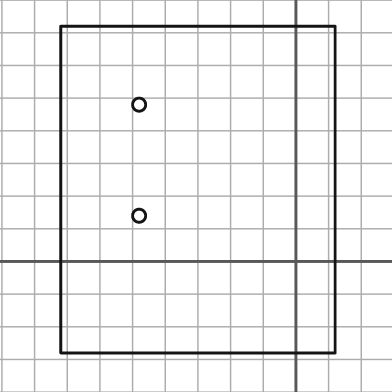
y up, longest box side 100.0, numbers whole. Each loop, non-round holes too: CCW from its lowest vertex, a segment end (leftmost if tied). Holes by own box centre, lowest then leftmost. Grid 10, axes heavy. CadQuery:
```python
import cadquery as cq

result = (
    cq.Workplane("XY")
    .moveTo(-72.0, -28.0)
    .lineTo(12.0, -28.0)
    .lineTo(12.0, 72.0)
    .lineTo(-72.0, 72.0)
    .close()
    .moveTo(-48.0, 14.0)
    .circle(2.0)
    .moveTo(-48.0, 48.0)
    .circle(2.0)
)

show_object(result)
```